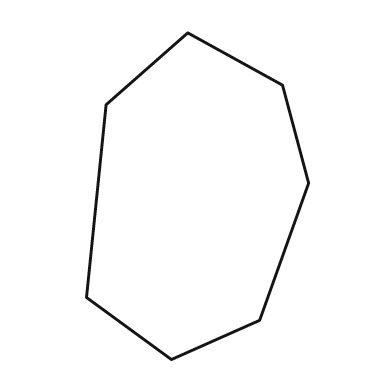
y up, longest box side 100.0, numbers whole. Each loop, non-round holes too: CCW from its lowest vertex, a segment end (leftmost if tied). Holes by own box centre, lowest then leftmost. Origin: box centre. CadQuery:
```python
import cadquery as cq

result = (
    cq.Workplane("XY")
    .moveTo(-8.0, -50.0)
    .lineTo(19.0, -38.0)
    .lineTo(34.0, 4.0)
    .lineTo(26.0, 34.0)
    .lineTo(-3.0, 50.0)
    .lineTo(-28.0, 28.0)
    .lineTo(-34.0, -31.0)
    .close()
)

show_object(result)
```